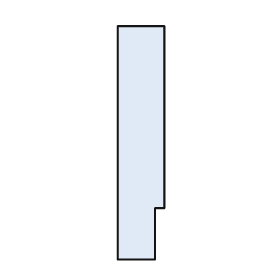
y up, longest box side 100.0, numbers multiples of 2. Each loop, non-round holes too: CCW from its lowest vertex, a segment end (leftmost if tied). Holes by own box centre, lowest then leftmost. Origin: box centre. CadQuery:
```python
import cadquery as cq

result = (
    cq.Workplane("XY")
    .moveTo(-10.0, -50.0)
    .lineTo(6.0, -50.0)
    .lineTo(6.0, -28.0)
    .lineTo(10.0, -28.0)
    .lineTo(10.0, 50.0)
    .lineTo(-10.0, 50.0)
    .close()
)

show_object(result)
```